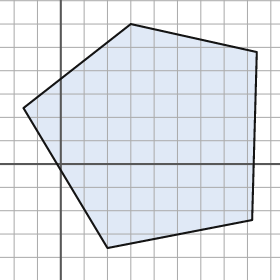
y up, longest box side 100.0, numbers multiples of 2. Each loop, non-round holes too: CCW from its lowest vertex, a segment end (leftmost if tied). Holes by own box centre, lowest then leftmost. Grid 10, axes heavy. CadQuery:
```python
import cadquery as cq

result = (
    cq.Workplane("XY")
    .moveTo(20.0, -36.0)
    .lineTo(82.0, -24.0)
    .lineTo(84.0, 48.0)
    .lineTo(30.0, 60.0)
    .lineTo(-16.0, 24.0)
    .close()
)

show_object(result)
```